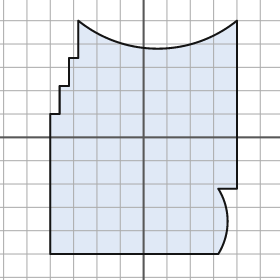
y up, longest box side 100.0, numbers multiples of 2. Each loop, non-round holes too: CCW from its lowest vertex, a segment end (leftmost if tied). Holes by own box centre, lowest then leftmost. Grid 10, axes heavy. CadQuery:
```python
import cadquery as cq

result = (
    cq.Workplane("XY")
    .moveTo(-40.0, -50.0)
    .lineTo(32.0, -50.0)
    .threePointArc((36.0, -36.0), (32.0, -22.0))
    .lineTo(40.0, -22.0)
    .lineTo(40.0, 50.0)
    .threePointArc((6.0, 38.0), (-28.0, 50.0))
    .lineTo(-28.0, 34.0)
    .lineTo(-32.0, 34.0)
    .lineTo(-32.0, 22.0)
    .lineTo(-36.0, 22.0)
    .lineTo(-36.0, 10.0)
    .lineTo(-40.0, 10.0)
    .close()
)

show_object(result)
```